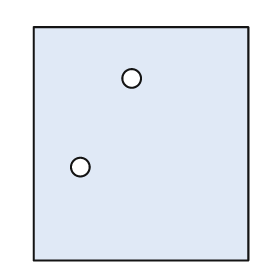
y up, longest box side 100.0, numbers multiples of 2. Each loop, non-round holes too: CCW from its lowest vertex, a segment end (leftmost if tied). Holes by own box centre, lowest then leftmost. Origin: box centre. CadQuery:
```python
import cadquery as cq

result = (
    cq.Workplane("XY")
    .moveTo(-46.0, -50.0)
    .lineTo(46.0, -50.0)
    .lineTo(46.0, 50.0)
    .lineTo(-46.0, 50.0)
    .close()
    .moveTo(-26.0, -10.0)
    .circle(4.0)
    .moveTo(-4.0, 28.0)
    .circle(4.0)
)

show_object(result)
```